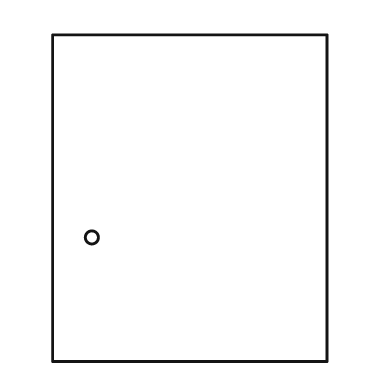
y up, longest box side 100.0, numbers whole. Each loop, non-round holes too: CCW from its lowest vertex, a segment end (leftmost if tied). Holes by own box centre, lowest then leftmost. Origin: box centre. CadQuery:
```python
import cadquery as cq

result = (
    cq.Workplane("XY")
    .moveTo(-42.0, -50.0)
    .lineTo(42.0, -50.0)
    .lineTo(42.0, 50.0)
    .lineTo(-42.0, 50.0)
    .close()
    .moveTo(-30.0, -12.0)
    .circle(2.0)
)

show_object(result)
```